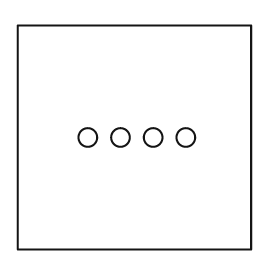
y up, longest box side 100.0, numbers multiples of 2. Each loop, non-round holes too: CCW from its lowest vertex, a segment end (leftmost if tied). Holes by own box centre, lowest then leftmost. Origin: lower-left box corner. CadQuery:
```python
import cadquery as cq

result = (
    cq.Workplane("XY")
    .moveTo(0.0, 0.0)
    .lineTo(100.0, 0.0)
    .lineTo(100.0, 96.0)
    .lineTo(0.0, 96.0)
    .close()
    .moveTo(30.0, 48.0)
    .circle(4.0)
    .moveTo(44.0, 48.0)
    .circle(4.0)
    .moveTo(58.0, 48.0)
    .circle(4.0)
    .moveTo(72.0, 48.0)
    .circle(4.0)
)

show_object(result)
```